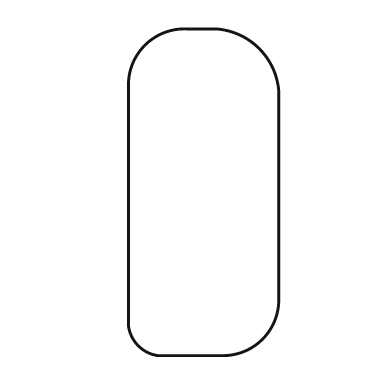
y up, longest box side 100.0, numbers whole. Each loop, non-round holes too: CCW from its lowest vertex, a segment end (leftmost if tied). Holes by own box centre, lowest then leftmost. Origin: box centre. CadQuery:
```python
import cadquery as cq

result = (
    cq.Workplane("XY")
    .moveTo(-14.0, -50.0)
    .lineTo(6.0, -50.0)
    .threePointArc((18.0, -45.0), (23.0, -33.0))
    .lineTo(23.0, 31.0)
    .threePointArc((17.0, 44.0), (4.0, 50.0))
    .lineTo(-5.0, 50.0)
    .threePointArc((-18.0, 45.0), (-23.0, 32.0))
    .lineTo(-23.0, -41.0)
    .threePointArc((-20.0, -47.0), (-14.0, -50.0))
    .close()
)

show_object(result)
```